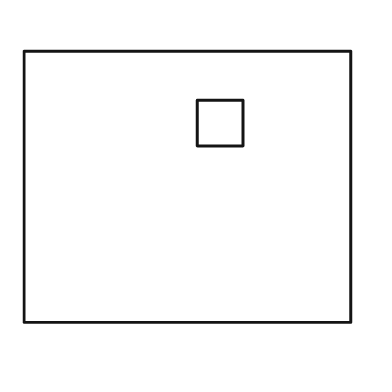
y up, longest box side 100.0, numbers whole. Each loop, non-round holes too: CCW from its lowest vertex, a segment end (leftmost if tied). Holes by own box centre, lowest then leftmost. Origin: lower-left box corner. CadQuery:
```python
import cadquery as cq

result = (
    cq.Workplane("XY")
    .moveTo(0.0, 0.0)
    .lineTo(100.0, 0.0)
    .lineTo(100.0, 83.0)
    .lineTo(0.0, 83.0)
    .close()
    .moveTo(53.0, 54.0)
    .lineTo(67.0, 54.0)
    .lineTo(67.0, 68.0)
    .lineTo(53.0, 68.0)
    .close()
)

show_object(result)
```